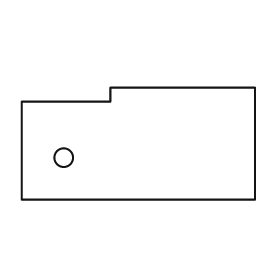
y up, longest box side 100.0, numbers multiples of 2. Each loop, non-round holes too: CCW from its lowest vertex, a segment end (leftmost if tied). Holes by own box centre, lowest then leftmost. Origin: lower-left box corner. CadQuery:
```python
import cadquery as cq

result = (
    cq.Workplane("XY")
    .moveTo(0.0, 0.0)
    .lineTo(100.0, 0.0)
    .lineTo(100.0, 48.0)
    .lineTo(38.0, 48.0)
    .lineTo(38.0, 42.0)
    .lineTo(0.0, 42.0)
    .close()
    .moveTo(18.0, 18.0)
    .circle(4.0)
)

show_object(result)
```